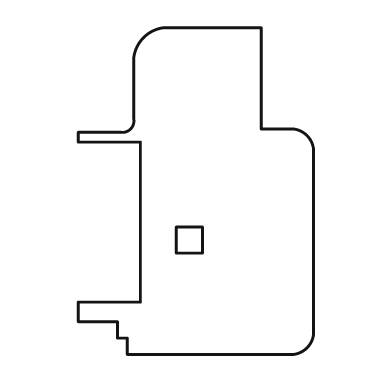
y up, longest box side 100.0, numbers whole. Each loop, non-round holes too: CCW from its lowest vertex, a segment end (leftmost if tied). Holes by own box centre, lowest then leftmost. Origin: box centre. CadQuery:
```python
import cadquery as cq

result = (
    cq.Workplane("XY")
    .moveTo(-21.0, -50.0)
    .lineTo(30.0, -50.0)
    .threePointArc((34.0, -48.0), (36.0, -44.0))
    .lineTo(36.0, 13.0)
    .threePointArc((34.0, 17.0), (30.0, 19.0))
    .lineTo(20.0, 19.0)
    .lineTo(20.0, 50.0)
    .lineTo(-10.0, 50.0)
    .threePointArc((-16.0, 47.0), (-19.0, 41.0))
    .lineTo(-19.0, 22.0)
    .threePointArc((-20.0, 19.0), (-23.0, 18.0))
    .lineTo(-36.0, 18.0)
    .lineTo(-36.0, 15.0)
    .lineTo(-17.0, 15.0)
    .lineTo(-17.0, -34.0)
    .lineTo(-36.0, -34.0)
    .lineTo(-36.0, -40.0)
    .lineTo(-24.0, -40.0)
    .lineTo(-24.0, -45.0)
    .lineTo(-21.0, -45.0)
    .close()
    .moveTo(-6.0, -19.0)
    .lineTo(2.0, -19.0)
    .lineTo(2.0, -11.0)
    .lineTo(-6.0, -11.0)
    .close()
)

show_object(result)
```